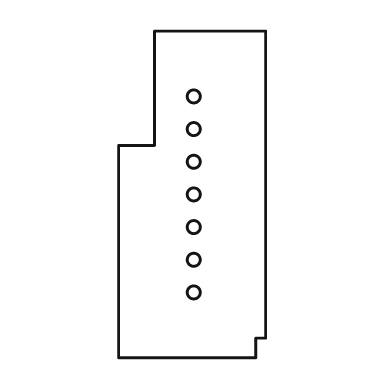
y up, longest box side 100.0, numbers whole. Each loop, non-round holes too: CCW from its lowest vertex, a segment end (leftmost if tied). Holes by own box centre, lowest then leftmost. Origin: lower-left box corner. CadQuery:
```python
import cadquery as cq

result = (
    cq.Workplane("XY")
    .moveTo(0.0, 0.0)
    .lineTo(42.0, 0.0)
    .lineTo(42.0, 6.0)
    .lineTo(45.0, 6.0)
    .lineTo(45.0, 100.0)
    .lineTo(11.0, 100.0)
    .lineTo(11.0, 65.0)
    .lineTo(0.0, 65.0)
    .close()
    .moveTo(23.0, 20.0)
    .circle(2.0)
    .moveTo(23.0, 30.0)
    .circle(2.0)
    .moveTo(23.0, 40.0)
    .circle(2.0)
    .moveTo(23.0, 50.0)
    .circle(2.0)
    .moveTo(23.0, 60.0)
    .circle(2.0)
    .moveTo(23.0, 70.0)
    .circle(2.0)
    .moveTo(23.0, 80.0)
    .circle(2.0)
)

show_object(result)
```